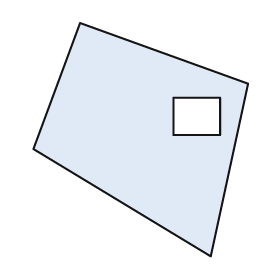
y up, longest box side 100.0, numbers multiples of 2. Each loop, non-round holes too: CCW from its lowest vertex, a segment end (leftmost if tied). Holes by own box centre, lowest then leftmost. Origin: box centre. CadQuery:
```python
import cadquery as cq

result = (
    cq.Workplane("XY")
    .moveTo(30.0, -50.0)
    .lineTo(46.0, 24.0)
    .lineTo(-26.0, 50.0)
    .lineTo(-46.0, -4.0)
    .close()
    .moveTo(14.0, 2.0)
    .lineTo(34.0, 2.0)
    .lineTo(34.0, 18.0)
    .lineTo(14.0, 18.0)
    .close()
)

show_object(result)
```